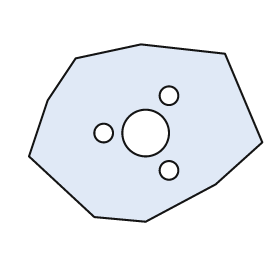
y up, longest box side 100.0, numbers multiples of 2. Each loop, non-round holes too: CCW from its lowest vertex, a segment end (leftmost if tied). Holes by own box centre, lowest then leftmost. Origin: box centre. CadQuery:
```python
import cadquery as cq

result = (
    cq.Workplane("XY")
    .moveTo(0.0, -38.0)
    .lineTo(30.0, -22.0)
    .lineTo(50.0, -4.0)
    .lineTo(34.0, 34.0)
    .lineTo(-2.0, 38.0)
    .lineTo(-30.0, 32.0)
    .lineTo(-42.0, 14.0)
    .lineTo(-50.0, -10.0)
    .lineTo(-22.0, -36.0)
    .close()
    .moveTo(10.0, -16.0)
    .circle(4.0)
    .moveTo(-18.0, 0.0)
    .circle(4.0)
    .moveTo(0.0, 0.0)
    .circle(10.0)
    .moveTo(10.0, 16.0)
    .circle(4.0)
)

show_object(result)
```